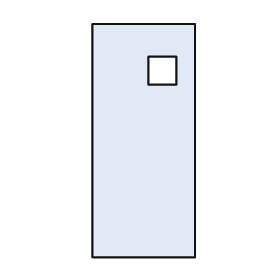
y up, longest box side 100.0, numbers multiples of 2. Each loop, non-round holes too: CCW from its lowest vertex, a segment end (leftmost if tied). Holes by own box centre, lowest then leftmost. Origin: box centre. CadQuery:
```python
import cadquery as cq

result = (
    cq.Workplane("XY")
    .moveTo(-22.0, -50.0)
    .lineTo(22.0, -50.0)
    .lineTo(22.0, 50.0)
    .lineTo(-22.0, 50.0)
    .close()
    .moveTo(2.0, 24.0)
    .lineTo(14.0, 24.0)
    .lineTo(14.0, 36.0)
    .lineTo(2.0, 36.0)
    .close()
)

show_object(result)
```